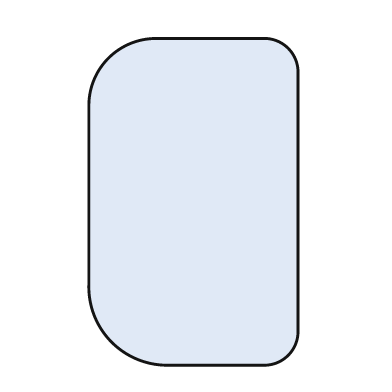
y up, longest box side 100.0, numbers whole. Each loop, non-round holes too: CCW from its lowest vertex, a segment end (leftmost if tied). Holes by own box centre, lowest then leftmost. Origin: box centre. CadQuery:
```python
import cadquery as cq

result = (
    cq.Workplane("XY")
    .moveTo(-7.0, -50.0)
    .lineTo(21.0, -50.0)
    .threePointArc((29.0, -47.0), (32.0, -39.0))
    .lineTo(32.0, 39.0)
    .threePointArc((29.0, 47.0), (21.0, 50.0))
    .lineTo(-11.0, 50.0)
    .threePointArc((-26.0, 44.0), (-32.0, 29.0))
    .lineTo(-32.0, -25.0)
    .threePointArc((-25.0, -43.0), (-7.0, -50.0))
    .close()
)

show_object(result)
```